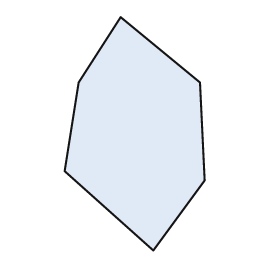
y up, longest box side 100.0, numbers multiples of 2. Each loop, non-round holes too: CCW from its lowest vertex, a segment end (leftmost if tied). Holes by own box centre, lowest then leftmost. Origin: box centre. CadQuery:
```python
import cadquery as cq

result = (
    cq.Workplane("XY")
    .moveTo(8.0, -50.0)
    .lineTo(30.0, -20.0)
    .lineTo(28.0, 22.0)
    .lineTo(-6.0, 50.0)
    .lineTo(-24.0, 22.0)
    .lineTo(-30.0, -16.0)
    .close()
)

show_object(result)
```